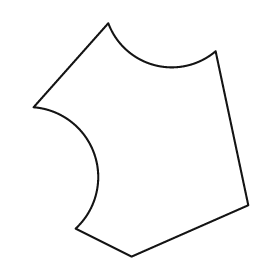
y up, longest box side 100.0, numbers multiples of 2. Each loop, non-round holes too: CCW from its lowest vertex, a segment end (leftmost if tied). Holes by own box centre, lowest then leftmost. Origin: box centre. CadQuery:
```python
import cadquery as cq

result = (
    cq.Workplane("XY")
    .moveTo(-4.0, -50.0)
    .lineTo(46.0, -28.0)
    .lineTo(32.0, 38.0)
    .threePointArc((6.0, 32.0), (-14.0, 50.0))
    .lineTo(-46.0, 14.0)
    .threePointArc((-20.0, -6.0), (-28.0, -38.0))
    .close()
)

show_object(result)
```